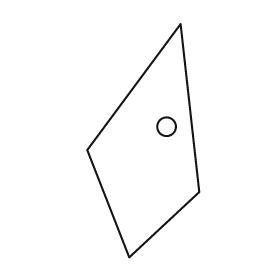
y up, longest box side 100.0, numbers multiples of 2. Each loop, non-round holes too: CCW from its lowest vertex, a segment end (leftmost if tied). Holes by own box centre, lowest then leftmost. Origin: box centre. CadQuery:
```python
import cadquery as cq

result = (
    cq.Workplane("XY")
    .moveTo(-6.0, -50.0)
    .lineTo(24.0, -22.0)
    .lineTo(16.0, 50.0)
    .lineTo(-24.0, -4.0)
    .close()
    .moveTo(10.0, 6.0)
    .circle(4.0)
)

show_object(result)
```